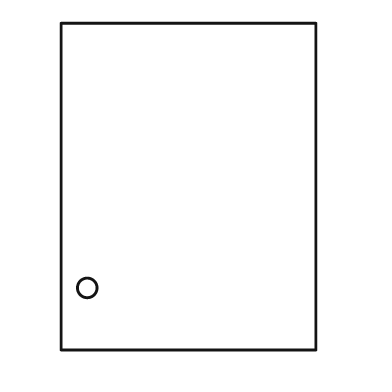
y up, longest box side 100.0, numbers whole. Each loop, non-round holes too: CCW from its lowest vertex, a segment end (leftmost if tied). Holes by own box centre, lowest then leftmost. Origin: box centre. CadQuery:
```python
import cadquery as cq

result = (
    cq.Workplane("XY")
    .moveTo(-39.0, -50.0)
    .lineTo(39.0, -50.0)
    .lineTo(39.0, 50.0)
    .lineTo(-39.0, 50.0)
    .close()
    .moveTo(-31.0, -31.0)
    .circle(3.0)
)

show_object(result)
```